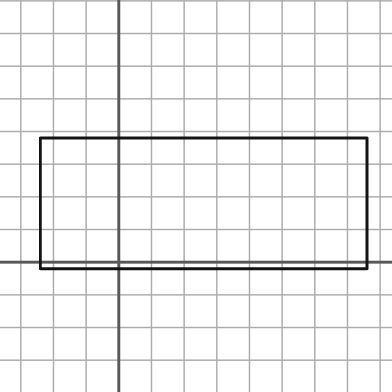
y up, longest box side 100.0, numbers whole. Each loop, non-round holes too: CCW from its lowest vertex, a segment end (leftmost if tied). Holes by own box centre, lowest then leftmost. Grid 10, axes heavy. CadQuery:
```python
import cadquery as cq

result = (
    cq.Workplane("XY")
    .moveTo(-24.0, -2.0)
    .lineTo(76.0, -2.0)
    .lineTo(76.0, 38.0)
    .lineTo(-24.0, 38.0)
    .close()
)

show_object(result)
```